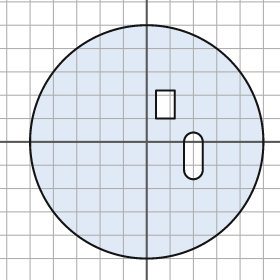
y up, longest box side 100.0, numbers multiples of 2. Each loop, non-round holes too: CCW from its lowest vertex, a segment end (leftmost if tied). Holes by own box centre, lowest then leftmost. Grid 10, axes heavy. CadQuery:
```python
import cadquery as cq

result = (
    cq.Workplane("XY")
    .moveTo(0.0, 0.0)
    .circle(50.0)
    .moveTo(16.0, -12.0)
    .threePointArc((20.0, -16.0), (24.0, -12.0))
    .lineTo(24.0, 0.0)
    .threePointArc((20.0, 4.0), (16.0, 0.0))
    .close()
    .moveTo(4.0, 10.0)
    .lineTo(12.0, 10.0)
    .lineTo(12.0, 22.0)
    .lineTo(4.0, 22.0)
    .close()
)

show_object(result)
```